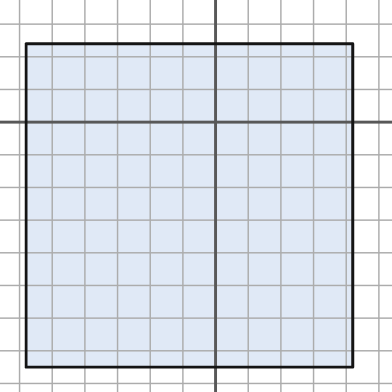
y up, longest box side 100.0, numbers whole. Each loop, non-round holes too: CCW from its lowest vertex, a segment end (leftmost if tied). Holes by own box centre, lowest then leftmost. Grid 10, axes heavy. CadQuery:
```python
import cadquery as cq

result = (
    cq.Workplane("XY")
    .moveTo(-58.0, -75.0)
    .lineTo(42.0, -75.0)
    .lineTo(42.0, 24.0)
    .lineTo(-58.0, 24.0)
    .close()
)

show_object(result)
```